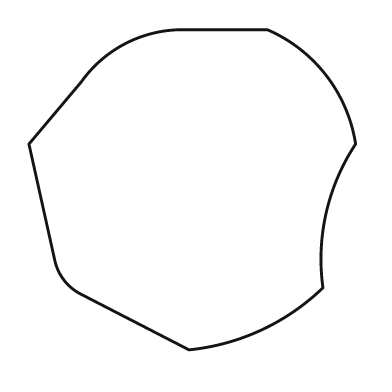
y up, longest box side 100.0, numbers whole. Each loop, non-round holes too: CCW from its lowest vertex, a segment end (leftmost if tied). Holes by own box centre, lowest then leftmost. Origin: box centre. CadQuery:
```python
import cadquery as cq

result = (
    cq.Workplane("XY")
    .moveTo(-1.0, -49.0)
    .threePointArc((21.0, -43.0), (40.0, -30.0))
    .threePointArc((41.0, -7.0), (50.0, 14.0))
    .threePointArc((41.0, 35.0), (23.0, 49.0))
    .lineTo(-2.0, 49.0)
    .threePointArc((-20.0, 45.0), (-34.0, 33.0))
    .lineTo(-50.0, 14.0)
    .lineTo(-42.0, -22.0)
    .threePointArc((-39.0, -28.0), (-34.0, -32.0))
    .close()
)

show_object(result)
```